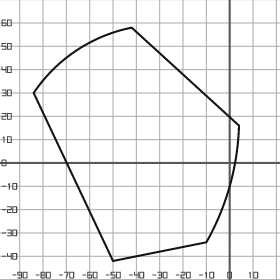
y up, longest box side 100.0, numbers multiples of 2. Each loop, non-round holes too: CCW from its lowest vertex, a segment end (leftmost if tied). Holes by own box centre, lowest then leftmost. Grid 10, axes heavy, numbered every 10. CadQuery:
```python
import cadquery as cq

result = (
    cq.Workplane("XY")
    .moveTo(-50.0, -42.0)
    .lineTo(-10.0, -34.0)
    .threePointArc((0.0, -10.0), (4.0, 16.0))
    .lineTo(-42.0, 58.0)
    .threePointArc((-66.0, 48.0), (-84.0, 30.0))
    .close()
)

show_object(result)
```